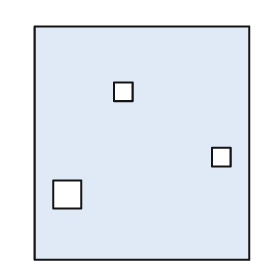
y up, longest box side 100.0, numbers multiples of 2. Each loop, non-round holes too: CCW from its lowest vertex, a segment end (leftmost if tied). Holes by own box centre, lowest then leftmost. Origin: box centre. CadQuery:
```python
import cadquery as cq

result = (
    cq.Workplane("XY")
    .moveTo(-46.0, -50.0)
    .lineTo(46.0, -50.0)
    .lineTo(46.0, 50.0)
    .lineTo(-46.0, 50.0)
    .close()
    .moveTo(-38.0, -28.0)
    .lineTo(-26.0, -28.0)
    .lineTo(-26.0, -16.0)
    .lineTo(-38.0, -16.0)
    .close()
    .moveTo(30.0, -10.0)
    .lineTo(38.0, -10.0)
    .lineTo(38.0, -2.0)
    .lineTo(30.0, -2.0)
    .close()
    .moveTo(-12.0, 18.0)
    .lineTo(-4.0, 18.0)
    .lineTo(-4.0, 26.0)
    .lineTo(-12.0, 26.0)
    .close()
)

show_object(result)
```